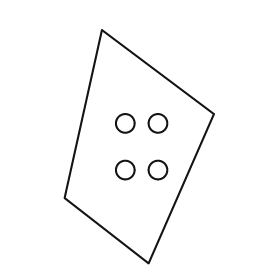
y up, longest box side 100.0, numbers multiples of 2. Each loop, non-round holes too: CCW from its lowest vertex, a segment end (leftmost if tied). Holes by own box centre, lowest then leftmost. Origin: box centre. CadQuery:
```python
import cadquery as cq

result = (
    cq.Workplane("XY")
    .moveTo(4.0, -50.0)
    .lineTo(32.0, 14.0)
    .lineTo(-16.0, 50.0)
    .lineTo(-32.0, -22.0)
    .close()
    .moveTo(-6.0, -10.0)
    .circle(4.0)
    .moveTo(8.0, -10.0)
    .circle(4.0)
    .moveTo(-6.0, 10.0)
    .circle(4.0)
    .moveTo(8.0, 10.0)
    .circle(4.0)
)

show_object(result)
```